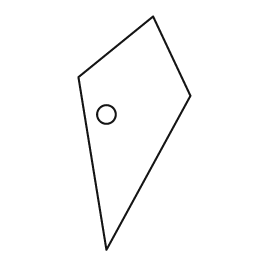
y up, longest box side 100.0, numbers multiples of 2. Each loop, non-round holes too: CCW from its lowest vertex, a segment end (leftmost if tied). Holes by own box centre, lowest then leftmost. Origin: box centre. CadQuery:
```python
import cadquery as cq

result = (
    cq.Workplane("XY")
    .moveTo(-12.0, -50.0)
    .lineTo(24.0, 16.0)
    .lineTo(8.0, 50.0)
    .lineTo(-24.0, 24.0)
    .close()
    .moveTo(-12.0, 8.0)
    .circle(4.0)
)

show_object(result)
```